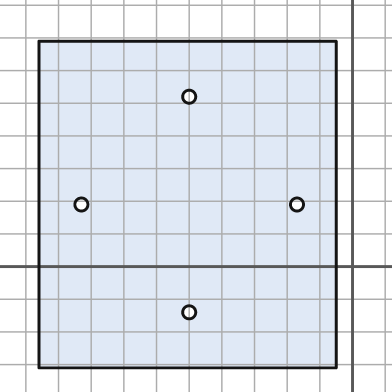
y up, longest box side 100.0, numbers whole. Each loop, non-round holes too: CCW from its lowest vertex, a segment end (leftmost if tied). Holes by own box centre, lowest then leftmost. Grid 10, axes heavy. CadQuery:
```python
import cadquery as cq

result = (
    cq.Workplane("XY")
    .moveTo(-96.0, -31.0)
    .lineTo(-5.0, -31.0)
    .lineTo(-5.0, 69.0)
    .lineTo(-96.0, 69.0)
    .close()
    .moveTo(-50.0, -14.0)
    .circle(2.0)
    .moveTo(-83.0, 19.0)
    .circle(2.0)
    .moveTo(-17.0, 19.0)
    .circle(2.0)
    .moveTo(-50.0, 52.0)
    .circle(2.0)
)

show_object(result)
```